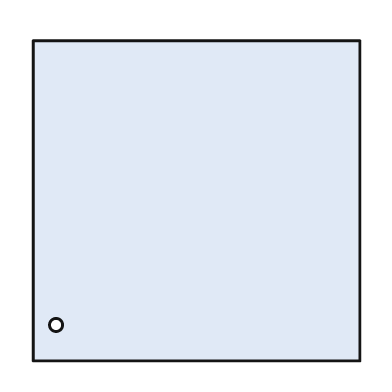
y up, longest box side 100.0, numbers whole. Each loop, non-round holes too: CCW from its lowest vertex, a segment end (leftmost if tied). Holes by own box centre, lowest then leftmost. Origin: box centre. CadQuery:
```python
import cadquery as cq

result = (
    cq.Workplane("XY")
    .moveTo(-50.0, -49.0)
    .lineTo(50.0, -49.0)
    .lineTo(50.0, 49.0)
    .lineTo(-50.0, 49.0)
    .close()
    .moveTo(-43.0, -38.0)
    .circle(2.0)
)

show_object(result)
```